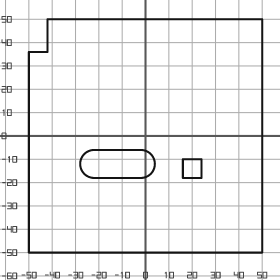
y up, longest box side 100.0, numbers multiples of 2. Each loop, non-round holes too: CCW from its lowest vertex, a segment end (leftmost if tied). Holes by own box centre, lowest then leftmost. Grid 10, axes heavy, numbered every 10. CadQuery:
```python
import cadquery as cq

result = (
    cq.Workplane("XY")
    .moveTo(-50.0, -50.0)
    .lineTo(50.0, -50.0)
    .lineTo(50.0, 50.0)
    .lineTo(-42.0, 50.0)
    .lineTo(-42.0, 36.0)
    .lineTo(-50.0, 36.0)
    .close()
    .moveTo(16.0, -18.0)
    .lineTo(24.0, -18.0)
    .lineTo(24.0, -10.0)
    .lineTo(16.0, -10.0)
    .close()
    .moveTo(-22.0, -18.0)
    .lineTo(-2.0, -18.0)
    .threePointArc((4.0, -12.0), (-2.0, -6.0))
    .lineTo(-22.0, -6.0)
    .threePointArc((-28.0, -12.0), (-22.0, -18.0))
    .close()
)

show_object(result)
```